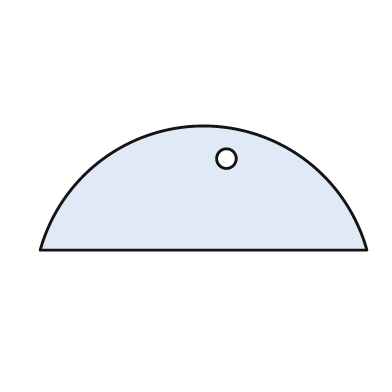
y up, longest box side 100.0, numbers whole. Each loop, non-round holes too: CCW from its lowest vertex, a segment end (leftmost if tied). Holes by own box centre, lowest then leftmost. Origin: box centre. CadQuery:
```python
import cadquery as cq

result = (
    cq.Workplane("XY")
    .moveTo(-50.0, -19.0)
    .lineTo(50.0, -19.0)
    .threePointArc((0.0, 19.0), (-50.0, -19.0))
    .close()
    .moveTo(7.0, 9.0)
    .circle(3.0)
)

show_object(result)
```